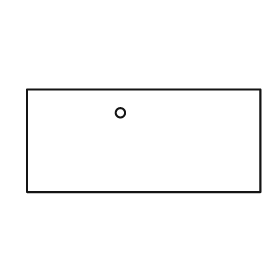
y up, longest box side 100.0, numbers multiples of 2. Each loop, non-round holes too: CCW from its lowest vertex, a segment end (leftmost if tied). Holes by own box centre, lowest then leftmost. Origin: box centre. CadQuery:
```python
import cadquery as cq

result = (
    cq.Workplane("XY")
    .moveTo(-50.0, -22.0)
    .lineTo(50.0, -22.0)
    .lineTo(50.0, 22.0)
    .lineTo(-50.0, 22.0)
    .close()
    .moveTo(-10.0, 12.0)
    .circle(2.0)
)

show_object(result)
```